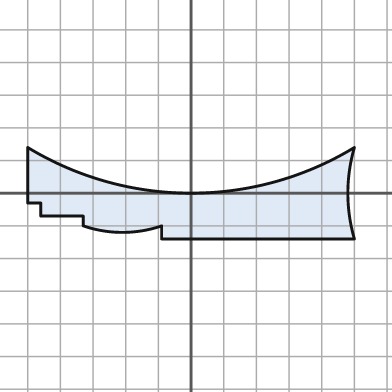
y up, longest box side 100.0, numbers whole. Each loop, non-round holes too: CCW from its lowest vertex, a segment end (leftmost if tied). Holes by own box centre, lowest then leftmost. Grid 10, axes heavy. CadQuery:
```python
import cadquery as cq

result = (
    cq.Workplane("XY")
    .moveTo(-9.0, -14.0)
    .lineTo(50.0, -14.0)
    .threePointArc((48.0, 0.0), (50.0, 14.0))
    .threePointArc((0.0, 0.0), (-50.0, 14.0))
    .lineTo(-50.0, -3.0)
    .lineTo(-46.0, -3.0)
    .lineTo(-46.0, -7.0)
    .lineTo(-33.0, -7.0)
    .lineTo(-33.0, -10.0)
    .threePointArc((-21.0, -12.0), (-9.0, -10.0))
    .close()
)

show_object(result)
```